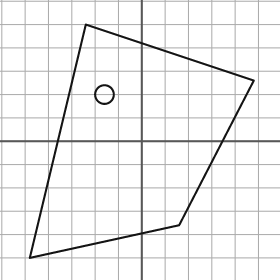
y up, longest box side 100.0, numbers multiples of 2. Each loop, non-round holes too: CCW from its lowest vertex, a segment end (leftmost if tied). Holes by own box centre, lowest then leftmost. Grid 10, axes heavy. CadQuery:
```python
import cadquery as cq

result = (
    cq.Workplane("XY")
    .moveTo(-48.0, -50.0)
    .lineTo(16.0, -36.0)
    .lineTo(48.0, 26.0)
    .lineTo(-24.0, 50.0)
    .close()
    .moveTo(-16.0, 20.0)
    .circle(4.0)
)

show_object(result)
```